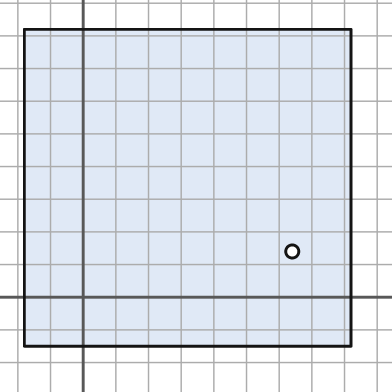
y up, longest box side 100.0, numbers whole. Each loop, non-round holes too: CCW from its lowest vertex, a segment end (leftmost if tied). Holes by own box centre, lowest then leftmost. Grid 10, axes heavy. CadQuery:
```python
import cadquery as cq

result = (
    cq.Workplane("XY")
    .moveTo(-18.0, -15.0)
    .lineTo(82.0, -15.0)
    .lineTo(82.0, 82.0)
    .lineTo(-18.0, 82.0)
    .close()
    .moveTo(64.0, 14.0)
    .circle(2.0)
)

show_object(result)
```